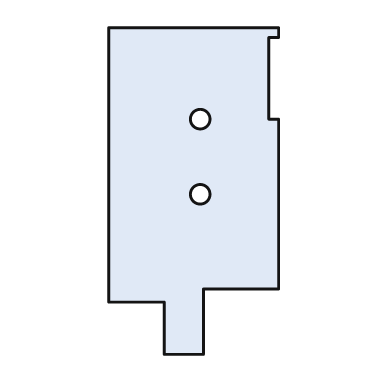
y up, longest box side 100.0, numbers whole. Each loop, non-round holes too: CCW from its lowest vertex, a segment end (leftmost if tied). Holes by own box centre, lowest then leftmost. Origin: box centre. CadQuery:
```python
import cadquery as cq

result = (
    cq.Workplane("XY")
    .moveTo(-9.0, -50.0)
    .lineTo(3.0, -50.0)
    .lineTo(3.0, -30.0)
    .lineTo(26.0, -30.0)
    .lineTo(26.0, 22.0)
    .lineTo(23.0, 22.0)
    .lineTo(23.0, 47.0)
    .lineTo(26.0, 47.0)
    .lineTo(26.0, 50.0)
    .lineTo(-26.0, 50.0)
    .lineTo(-26.0, -34.0)
    .lineTo(-9.0, -34.0)
    .close()
    .moveTo(2.0, -1.0)
    .circle(3.0)
    .moveTo(2.0, 22.0)
    .circle(3.0)
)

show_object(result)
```